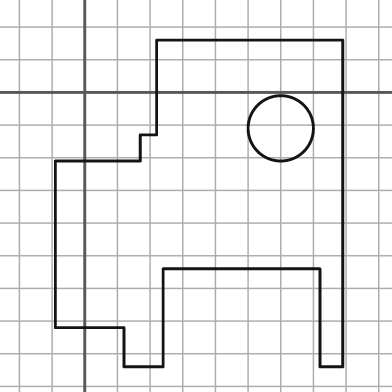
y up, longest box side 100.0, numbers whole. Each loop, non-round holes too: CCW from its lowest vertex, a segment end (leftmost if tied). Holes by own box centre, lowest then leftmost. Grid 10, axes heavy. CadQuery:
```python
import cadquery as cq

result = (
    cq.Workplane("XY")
    .moveTo(12.0, -84.0)
    .lineTo(24.0, -84.0)
    .lineTo(24.0, -54.0)
    .lineTo(72.0, -54.0)
    .lineTo(72.0, -84.0)
    .lineTo(79.0, -84.0)
    .lineTo(79.0, 16.0)
    .lineTo(22.0, 16.0)
    .lineTo(22.0, -13.0)
    .lineTo(17.0, -13.0)
    .lineTo(17.0, -21.0)
    .lineTo(-9.0, -21.0)
    .lineTo(-9.0, -72.0)
    .lineTo(12.0, -72.0)
    .close()
    .moveTo(60.0, -11.0)
    .circle(10.0)
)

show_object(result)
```